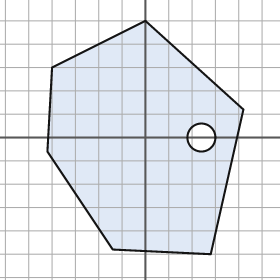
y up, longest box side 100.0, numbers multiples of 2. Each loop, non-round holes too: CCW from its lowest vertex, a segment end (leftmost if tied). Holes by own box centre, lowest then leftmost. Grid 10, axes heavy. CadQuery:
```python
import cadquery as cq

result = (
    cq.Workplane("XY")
    .moveTo(28.0, -50.0)
    .lineTo(42.0, 12.0)
    .lineTo(0.0, 50.0)
    .lineTo(-40.0, 30.0)
    .lineTo(-42.0, -6.0)
    .lineTo(-14.0, -48.0)
    .close()
    .moveTo(24.0, 0.0)
    .circle(6.0)
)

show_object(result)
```